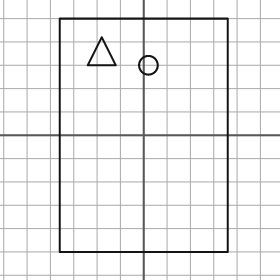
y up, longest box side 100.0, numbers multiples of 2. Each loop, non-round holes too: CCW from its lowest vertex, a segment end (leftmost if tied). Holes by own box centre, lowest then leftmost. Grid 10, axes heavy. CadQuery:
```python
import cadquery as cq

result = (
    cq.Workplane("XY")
    .moveTo(-36.0, -50.0)
    .lineTo(36.0, -50.0)
    .lineTo(36.0, 50.0)
    .lineTo(-36.0, 50.0)
    .close()
    .moveTo(2.0, 30.0)
    .circle(4.0)
    .moveTo(-24.0, 30.0)
    .lineTo(-12.0, 30.0)
    .lineTo(-18.0, 42.0)
    .close()
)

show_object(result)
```